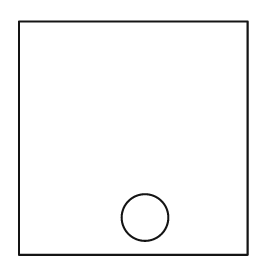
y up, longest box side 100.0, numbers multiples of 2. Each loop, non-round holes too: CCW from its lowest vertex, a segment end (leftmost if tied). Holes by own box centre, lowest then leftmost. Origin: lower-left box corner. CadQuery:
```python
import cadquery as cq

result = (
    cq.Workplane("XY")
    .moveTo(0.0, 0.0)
    .lineTo(98.0, 0.0)
    .lineTo(98.0, 100.0)
    .lineTo(0.0, 100.0)
    .close()
    .moveTo(54.0, 16.0)
    .circle(10.0)
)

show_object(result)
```